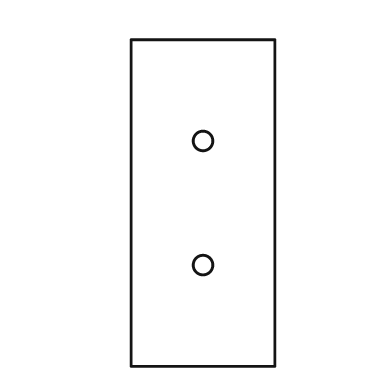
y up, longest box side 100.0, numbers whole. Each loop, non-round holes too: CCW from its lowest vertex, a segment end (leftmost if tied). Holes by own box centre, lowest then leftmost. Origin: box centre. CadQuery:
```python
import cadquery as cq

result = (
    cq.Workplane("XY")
    .moveTo(-22.0, -50.0)
    .lineTo(22.0, -50.0)
    .lineTo(22.0, 50.0)
    .lineTo(-22.0, 50.0)
    .close()
    .moveTo(0.0, -19.0)
    .circle(3.0)
    .moveTo(0.0, 19.0)
    .circle(3.0)
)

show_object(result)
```